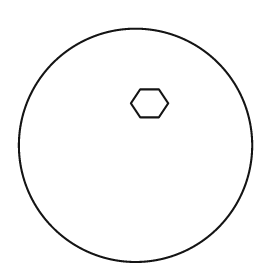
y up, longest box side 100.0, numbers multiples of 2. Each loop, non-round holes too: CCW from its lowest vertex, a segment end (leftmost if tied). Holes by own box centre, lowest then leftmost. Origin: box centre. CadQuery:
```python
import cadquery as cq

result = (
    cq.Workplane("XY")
    .moveTo(0.0, 0.0)
    .circle(50.0)
    .moveTo(2.0, 12.0)
    .lineTo(10.0, 12.0)
    .lineTo(14.0, 18.0)
    .lineTo(10.0, 24.0)
    .lineTo(2.0, 24.0)
    .lineTo(-2.0, 18.0)
    .close()
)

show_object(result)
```